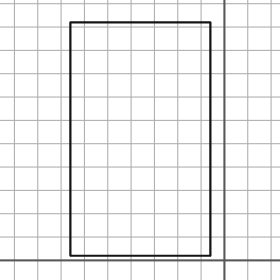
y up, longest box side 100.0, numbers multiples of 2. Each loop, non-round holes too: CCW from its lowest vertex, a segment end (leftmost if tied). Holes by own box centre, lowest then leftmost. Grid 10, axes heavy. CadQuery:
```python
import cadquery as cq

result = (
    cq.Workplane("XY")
    .moveTo(-66.0, 2.0)
    .lineTo(-6.0, 2.0)
    .lineTo(-6.0, 102.0)
    .lineTo(-66.0, 102.0)
    .close()
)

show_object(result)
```